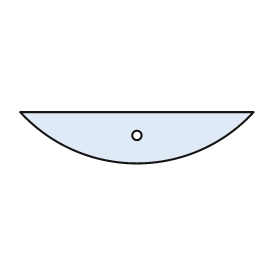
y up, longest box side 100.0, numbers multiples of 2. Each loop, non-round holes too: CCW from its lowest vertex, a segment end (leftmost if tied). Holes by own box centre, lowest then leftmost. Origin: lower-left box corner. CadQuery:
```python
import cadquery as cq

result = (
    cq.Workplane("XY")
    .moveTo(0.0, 22.0)
    .threePointArc((50.0, 0.0), (100.0, 22.0))
    .close()
    .moveTo(50.0, 12.0)
    .circle(2.0)
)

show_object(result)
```